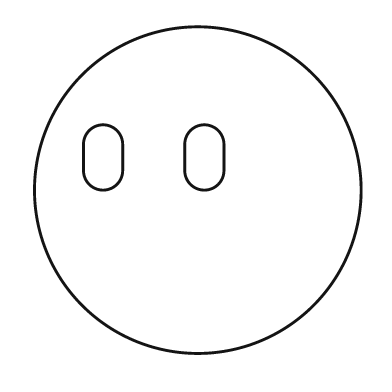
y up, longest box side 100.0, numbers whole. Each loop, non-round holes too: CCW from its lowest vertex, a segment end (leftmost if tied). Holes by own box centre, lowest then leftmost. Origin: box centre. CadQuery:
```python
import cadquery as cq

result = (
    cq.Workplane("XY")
    .moveTo(0.0, 0.0)
    .circle(50.0)
    .moveTo(-35.0, 6.0)
    .threePointArc((-29.0, 0.0), (-23.0, 6.0))
    .lineTo(-23.0, 14.0)
    .threePointArc((-29.0, 20.0), (-35.0, 14.0))
    .close()
    .moveTo(-4.0, 6.0)
    .threePointArc((2.0, 0.0), (8.0, 6.0))
    .lineTo(8.0, 14.0)
    .threePointArc((2.0, 20.0), (-4.0, 14.0))
    .close()
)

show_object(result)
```